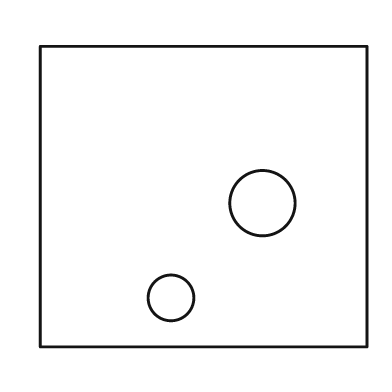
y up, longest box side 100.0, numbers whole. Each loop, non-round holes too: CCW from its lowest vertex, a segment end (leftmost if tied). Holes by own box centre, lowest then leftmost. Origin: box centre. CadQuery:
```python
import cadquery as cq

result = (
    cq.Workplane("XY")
    .moveTo(-50.0, -46.0)
    .lineTo(50.0, -46.0)
    .lineTo(50.0, 46.0)
    .lineTo(-50.0, 46.0)
    .close()
    .moveTo(-10.0, -31.0)
    .circle(7.0)
    .moveTo(18.0, -2.0)
    .circle(10.0)
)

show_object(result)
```